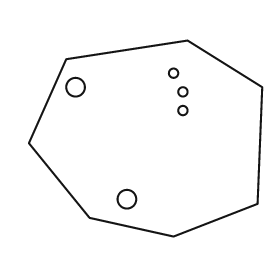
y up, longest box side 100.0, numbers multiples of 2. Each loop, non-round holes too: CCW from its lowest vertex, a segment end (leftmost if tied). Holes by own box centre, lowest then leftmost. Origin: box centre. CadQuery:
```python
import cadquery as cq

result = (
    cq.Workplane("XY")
    .moveTo(12.0, -42.0)
    .lineTo(48.0, -28.0)
    .lineTo(50.0, 22.0)
    .lineTo(18.0, 42.0)
    .lineTo(-34.0, 34.0)
    .lineTo(-50.0, -2.0)
    .lineTo(-24.0, -34.0)
    .close()
    .moveTo(-8.0, -26.0)
    .circle(4.0)
    .moveTo(16.0, 12.0)
    .circle(2.0)
    .moveTo(16.0, 20.0)
    .circle(2.0)
    .moveTo(-30.0, 22.0)
    .circle(4.0)
    .moveTo(12.0, 28.0)
    .circle(2.0)
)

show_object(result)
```